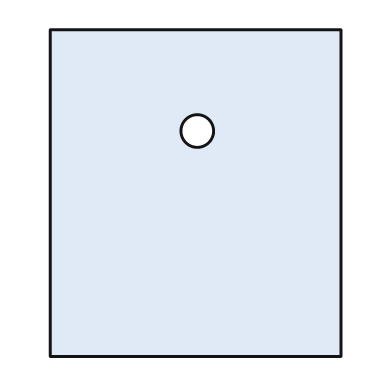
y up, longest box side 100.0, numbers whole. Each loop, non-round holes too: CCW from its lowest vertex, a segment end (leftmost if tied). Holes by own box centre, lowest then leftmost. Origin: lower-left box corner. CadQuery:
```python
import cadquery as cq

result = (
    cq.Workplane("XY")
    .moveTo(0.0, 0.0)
    .lineTo(89.0, 0.0)
    .lineTo(89.0, 100.0)
    .lineTo(0.0, 100.0)
    .close()
    .moveTo(45.0, 69.0)
    .circle(5.0)
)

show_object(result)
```